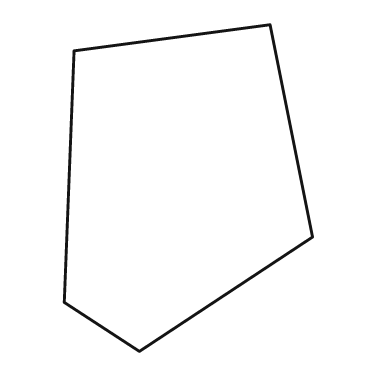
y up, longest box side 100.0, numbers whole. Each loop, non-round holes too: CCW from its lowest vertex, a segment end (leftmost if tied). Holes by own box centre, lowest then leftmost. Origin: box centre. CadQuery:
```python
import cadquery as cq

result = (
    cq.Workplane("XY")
    .moveTo(-15.0, -50.0)
    .lineTo(38.0, -15.0)
    .lineTo(25.0, 50.0)
    .lineTo(-35.0, 42.0)
    .lineTo(-38.0, -35.0)
    .close()
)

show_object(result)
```